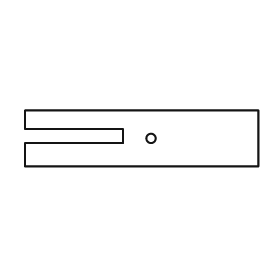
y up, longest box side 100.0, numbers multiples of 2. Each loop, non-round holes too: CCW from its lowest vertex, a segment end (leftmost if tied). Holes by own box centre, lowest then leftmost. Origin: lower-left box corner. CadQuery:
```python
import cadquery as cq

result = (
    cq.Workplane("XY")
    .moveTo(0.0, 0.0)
    .lineTo(100.0, 0.0)
    .lineTo(100.0, 24.0)
    .lineTo(0.0, 24.0)
    .lineTo(0.0, 16.0)
    .lineTo(42.0, 16.0)
    .lineTo(42.0, 10.0)
    .lineTo(0.0, 10.0)
    .close()
    .moveTo(54.0, 12.0)
    .circle(2.0)
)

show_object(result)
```